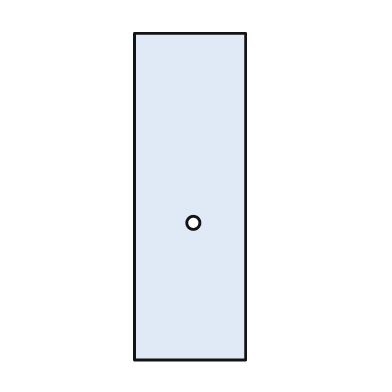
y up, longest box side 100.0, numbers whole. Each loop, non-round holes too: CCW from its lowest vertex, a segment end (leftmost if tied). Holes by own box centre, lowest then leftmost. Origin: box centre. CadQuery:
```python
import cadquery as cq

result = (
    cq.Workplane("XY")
    .moveTo(-17.0, -50.0)
    .lineTo(17.0, -50.0)
    .lineTo(17.0, 50.0)
    .lineTo(-17.0, 50.0)
    .close()
    .moveTo(1.0, -8.0)
    .circle(2.0)
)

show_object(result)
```